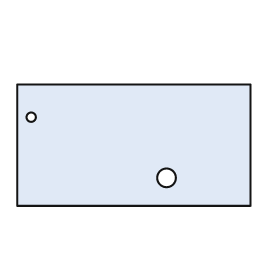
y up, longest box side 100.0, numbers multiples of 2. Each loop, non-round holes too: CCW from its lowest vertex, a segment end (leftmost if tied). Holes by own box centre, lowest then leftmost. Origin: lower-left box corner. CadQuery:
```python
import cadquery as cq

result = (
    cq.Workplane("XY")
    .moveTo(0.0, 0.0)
    .lineTo(100.0, 0.0)
    .lineTo(100.0, 52.0)
    .lineTo(0.0, 52.0)
    .close()
    .moveTo(64.0, 12.0)
    .circle(4.0)
    .moveTo(6.0, 38.0)
    .circle(2.0)
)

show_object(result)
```